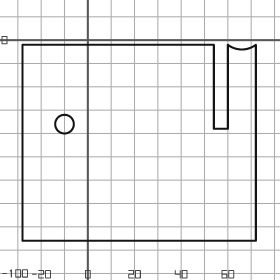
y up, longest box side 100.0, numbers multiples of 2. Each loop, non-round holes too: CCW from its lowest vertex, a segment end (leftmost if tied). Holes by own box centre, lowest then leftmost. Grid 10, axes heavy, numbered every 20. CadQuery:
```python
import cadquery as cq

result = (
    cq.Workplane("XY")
    .moveTo(-28.0, -86.0)
    .lineTo(72.0, -86.0)
    .lineTo(72.0, -2.0)
    .threePointArc((66.0, -4.0), (60.0, -2.0))
    .lineTo(60.0, -38.0)
    .lineTo(54.0, -38.0)
    .lineTo(54.0, -2.0)
    .lineTo(-28.0, -2.0)
    .close()
    .moveTo(-10.0, -36.0)
    .circle(4.0)
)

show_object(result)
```